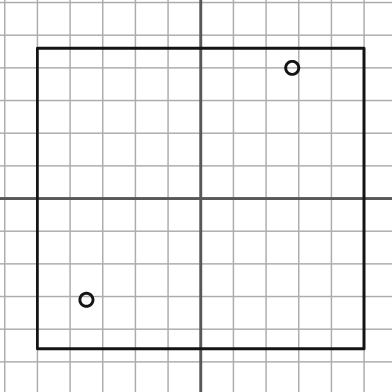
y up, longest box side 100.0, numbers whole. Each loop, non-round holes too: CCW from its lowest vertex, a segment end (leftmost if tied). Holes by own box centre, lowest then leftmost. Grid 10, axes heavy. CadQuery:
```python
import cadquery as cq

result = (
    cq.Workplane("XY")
    .moveTo(-50.0, -46.0)
    .lineTo(50.0, -46.0)
    .lineTo(50.0, 46.0)
    .lineTo(-50.0, 46.0)
    .close()
    .moveTo(-35.0, -31.0)
    .circle(2.0)
    .moveTo(28.0, 40.0)
    .circle(2.0)
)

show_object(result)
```